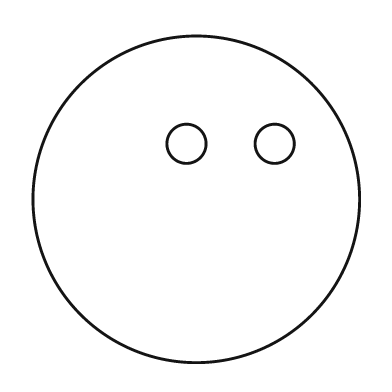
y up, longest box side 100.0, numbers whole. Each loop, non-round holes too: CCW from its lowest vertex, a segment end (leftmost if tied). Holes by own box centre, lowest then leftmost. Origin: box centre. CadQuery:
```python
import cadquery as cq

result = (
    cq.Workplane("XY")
    .moveTo(0.0, 0.0)
    .circle(50.0)
    .moveTo(-3.0, 17.0)
    .circle(6.0)
    .moveTo(24.0, 17.0)
    .circle(6.0)
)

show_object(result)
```